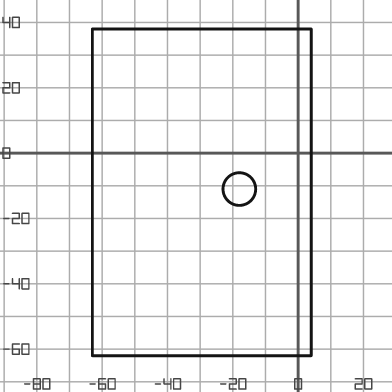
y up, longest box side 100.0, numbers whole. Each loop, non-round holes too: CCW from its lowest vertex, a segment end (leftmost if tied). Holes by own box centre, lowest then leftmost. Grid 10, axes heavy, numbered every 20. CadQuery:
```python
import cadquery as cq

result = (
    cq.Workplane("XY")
    .moveTo(-63.0, -62.0)
    .lineTo(4.0, -62.0)
    .lineTo(4.0, 38.0)
    .lineTo(-63.0, 38.0)
    .close()
    .moveTo(-18.0, -11.0)
    .circle(5.0)
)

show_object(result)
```